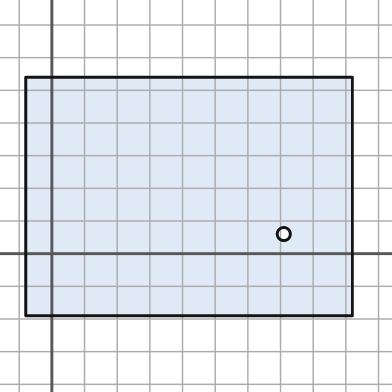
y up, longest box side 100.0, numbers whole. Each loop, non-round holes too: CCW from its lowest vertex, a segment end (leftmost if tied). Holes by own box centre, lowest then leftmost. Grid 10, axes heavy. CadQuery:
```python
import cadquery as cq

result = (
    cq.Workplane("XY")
    .moveTo(-8.0, -19.0)
    .lineTo(92.0, -19.0)
    .lineTo(92.0, 54.0)
    .lineTo(-8.0, 54.0)
    .close()
    .moveTo(71.0, 6.0)
    .circle(2.0)
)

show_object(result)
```